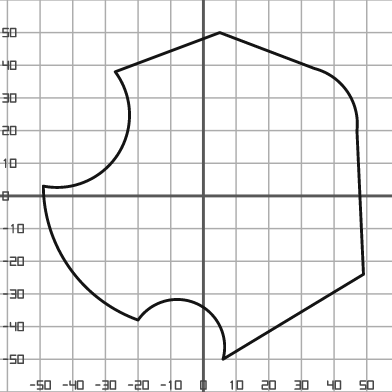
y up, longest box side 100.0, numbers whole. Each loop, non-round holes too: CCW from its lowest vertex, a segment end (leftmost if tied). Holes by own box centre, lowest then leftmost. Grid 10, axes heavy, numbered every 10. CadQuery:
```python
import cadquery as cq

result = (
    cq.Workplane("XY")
    .moveTo(6.0, -50.0)
    .lineTo(49.0, -24.0)
    .lineTo(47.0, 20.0)
    .threePointArc((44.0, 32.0), (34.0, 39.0))
    .lineTo(5.0, 50.0)
    .lineTo(-27.0, 38.0)
    .threePointArc((-26.0, 13.0), (-49.0, 3.0))
    .threePointArc((-41.0, -22.0), (-20.0, -38.0))
    .threePointArc((-2.0, -33.0), (6.0, -50.0))
    .close()
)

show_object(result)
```